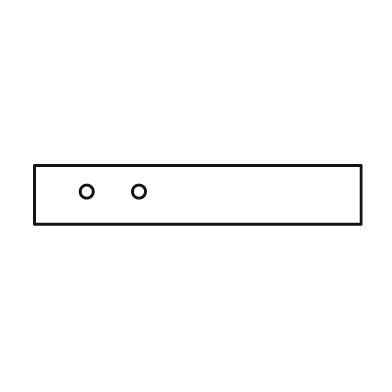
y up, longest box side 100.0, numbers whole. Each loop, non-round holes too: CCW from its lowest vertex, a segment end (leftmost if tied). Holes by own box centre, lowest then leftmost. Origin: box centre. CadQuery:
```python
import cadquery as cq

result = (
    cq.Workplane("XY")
    .moveTo(-50.0, -9.0)
    .lineTo(50.0, -9.0)
    .lineTo(50.0, 9.0)
    .lineTo(-50.0, 9.0)
    .close()
    .moveTo(-34.0, 1.0)
    .circle(2.0)
    .moveTo(-18.0, 1.0)
    .circle(2.0)
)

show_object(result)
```